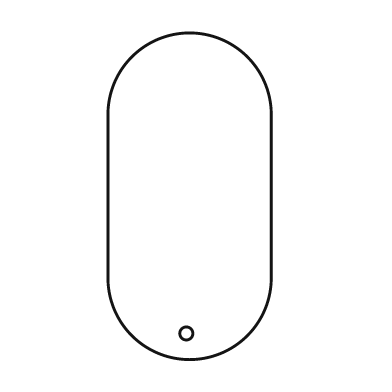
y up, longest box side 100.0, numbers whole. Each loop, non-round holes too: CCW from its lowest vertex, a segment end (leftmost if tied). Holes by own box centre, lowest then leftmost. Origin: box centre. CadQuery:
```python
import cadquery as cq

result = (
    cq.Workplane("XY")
    .moveTo(-25.0, -25.0)
    .threePointArc((0.0, -50.0), (25.0, -25.0))
    .lineTo(25.0, 25.0)
    .threePointArc((0.0, 50.0), (-25.0, 25.0))
    .close()
    .moveTo(-1.0, -42.0)
    .circle(2.0)
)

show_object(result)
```